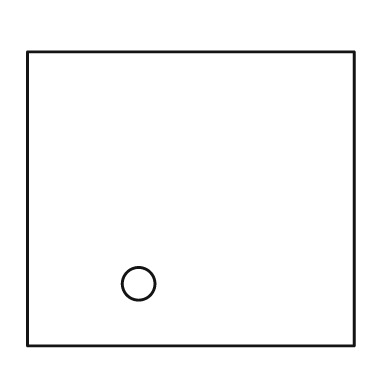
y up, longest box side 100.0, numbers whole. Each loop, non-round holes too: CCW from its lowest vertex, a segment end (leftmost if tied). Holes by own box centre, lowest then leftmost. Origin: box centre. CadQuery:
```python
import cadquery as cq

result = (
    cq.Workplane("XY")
    .moveTo(-50.0, -45.0)
    .lineTo(50.0, -45.0)
    .lineTo(50.0, 45.0)
    .lineTo(-50.0, 45.0)
    .close()
    .moveTo(-16.0, -26.0)
    .circle(5.0)
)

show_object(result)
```